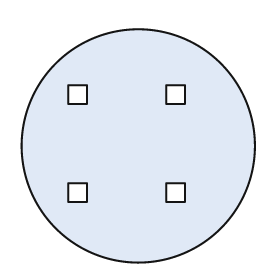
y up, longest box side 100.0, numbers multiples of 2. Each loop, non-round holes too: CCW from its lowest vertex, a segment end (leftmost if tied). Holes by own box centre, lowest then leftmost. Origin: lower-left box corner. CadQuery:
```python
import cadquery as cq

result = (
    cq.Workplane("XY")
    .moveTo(50.0, 50.0)
    .circle(50.0)
    .moveTo(20.0, 26.0)
    .lineTo(28.0, 26.0)
    .lineTo(28.0, 34.0)
    .lineTo(20.0, 34.0)
    .close()
    .moveTo(62.0, 26.0)
    .lineTo(70.0, 26.0)
    .lineTo(70.0, 34.0)
    .lineTo(62.0, 34.0)
    .close()
    .moveTo(20.0, 68.0)
    .lineTo(28.0, 68.0)
    .lineTo(28.0, 76.0)
    .lineTo(20.0, 76.0)
    .close()
    .moveTo(62.0, 68.0)
    .lineTo(70.0, 68.0)
    .lineTo(70.0, 76.0)
    .lineTo(62.0, 76.0)
    .close()
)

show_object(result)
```